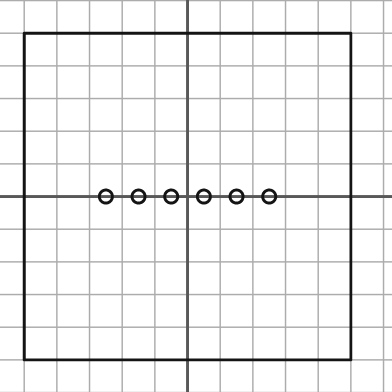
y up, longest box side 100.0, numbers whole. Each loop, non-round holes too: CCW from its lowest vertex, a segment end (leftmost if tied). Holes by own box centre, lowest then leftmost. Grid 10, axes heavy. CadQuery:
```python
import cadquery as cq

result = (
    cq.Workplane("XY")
    .moveTo(-50.0, -50.0)
    .lineTo(50.0, -50.0)
    .lineTo(50.0, 50.0)
    .lineTo(-50.0, 50.0)
    .close()
    .moveTo(-25.0, 0.0)
    .circle(2.0)
    .moveTo(-15.0, 0.0)
    .circle(2.0)
    .moveTo(-5.0, 0.0)
    .circle(2.0)
    .moveTo(5.0, 0.0)
    .circle(2.0)
    .moveTo(15.0, 0.0)
    .circle(2.0)
    .moveTo(25.0, 0.0)
    .circle(2.0)
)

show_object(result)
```